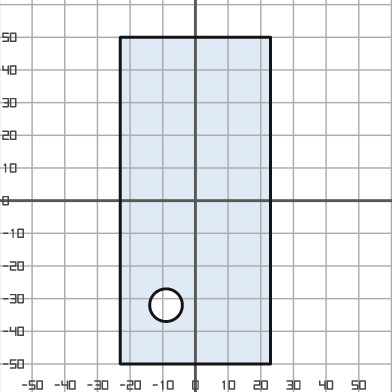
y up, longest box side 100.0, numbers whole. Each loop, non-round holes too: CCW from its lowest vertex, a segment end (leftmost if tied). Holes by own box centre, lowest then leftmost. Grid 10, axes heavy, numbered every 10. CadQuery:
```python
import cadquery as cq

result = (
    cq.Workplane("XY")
    .moveTo(-23.0, -50.0)
    .lineTo(23.0, -50.0)
    .lineTo(23.0, 50.0)
    .lineTo(-23.0, 50.0)
    .close()
    .moveTo(-9.0, -32.0)
    .circle(5.0)
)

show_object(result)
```